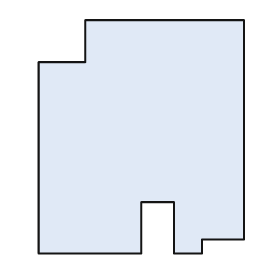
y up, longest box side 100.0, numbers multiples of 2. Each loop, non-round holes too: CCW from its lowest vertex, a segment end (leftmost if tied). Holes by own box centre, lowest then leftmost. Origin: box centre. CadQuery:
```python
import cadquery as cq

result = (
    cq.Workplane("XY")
    .moveTo(-44.0, -50.0)
    .lineTo(0.0, -50.0)
    .lineTo(0.0, -28.0)
    .lineTo(14.0, -28.0)
    .lineTo(14.0, -50.0)
    .lineTo(26.0, -50.0)
    .lineTo(26.0, -44.0)
    .lineTo(44.0, -44.0)
    .lineTo(44.0, 50.0)
    .lineTo(-24.0, 50.0)
    .lineTo(-24.0, 32.0)
    .lineTo(-44.0, 32.0)
    .close()
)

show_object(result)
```